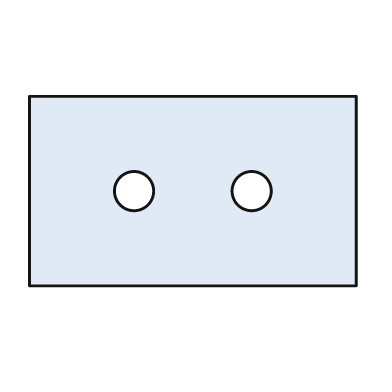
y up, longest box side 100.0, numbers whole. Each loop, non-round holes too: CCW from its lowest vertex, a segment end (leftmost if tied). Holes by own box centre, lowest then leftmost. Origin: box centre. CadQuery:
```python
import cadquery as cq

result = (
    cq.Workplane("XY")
    .moveTo(-50.0, -29.0)
    .lineTo(50.0, -29.0)
    .lineTo(50.0, 29.0)
    .lineTo(-50.0, 29.0)
    .close()
    .moveTo(-18.0, 0.0)
    .circle(6.0)
    .moveTo(18.0, 0.0)
    .circle(6.0)
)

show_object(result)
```